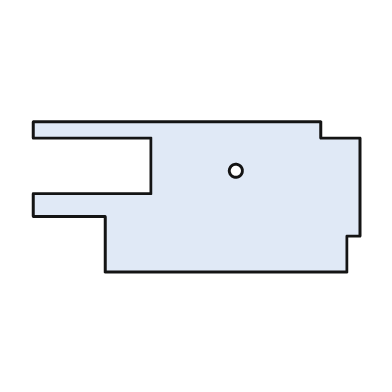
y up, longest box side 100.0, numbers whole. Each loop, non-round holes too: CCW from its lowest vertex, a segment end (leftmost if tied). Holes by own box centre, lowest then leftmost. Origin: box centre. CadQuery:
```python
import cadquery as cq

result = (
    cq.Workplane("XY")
    .moveTo(-28.0, -23.0)
    .lineTo(46.0, -23.0)
    .lineTo(46.0, -12.0)
    .lineTo(50.0, -12.0)
    .lineTo(50.0, 18.0)
    .lineTo(38.0, 18.0)
    .lineTo(38.0, 23.0)
    .lineTo(-50.0, 23.0)
    .lineTo(-50.0, 18.0)
    .lineTo(-14.0, 18.0)
    .lineTo(-14.0, 1.0)
    .lineTo(-50.0, 1.0)
    .lineTo(-50.0, -6.0)
    .lineTo(-28.0, -6.0)
    .close()
    .moveTo(12.0, 8.0)
    .circle(2.0)
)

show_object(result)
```